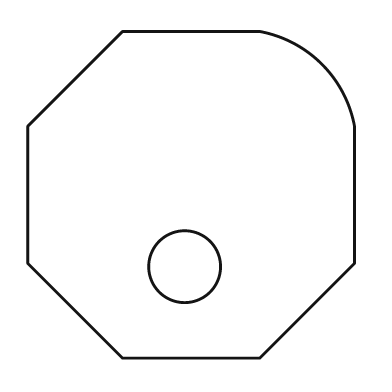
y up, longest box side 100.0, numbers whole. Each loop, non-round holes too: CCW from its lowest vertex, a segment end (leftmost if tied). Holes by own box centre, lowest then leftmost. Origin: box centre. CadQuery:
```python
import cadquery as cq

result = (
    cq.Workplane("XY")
    .moveTo(-21.0, -50.0)
    .lineTo(21.0, -50.0)
    .lineTo(50.0, -21.0)
    .lineTo(50.0, 21.0)
    .threePointArc((40.0, 40.0), (21.0, 50.0))
    .lineTo(-21.0, 50.0)
    .lineTo(-50.0, 21.0)
    .lineTo(-50.0, -21.0)
    .close()
    .moveTo(-2.0, -22.0)
    .circle(11.0)
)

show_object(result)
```